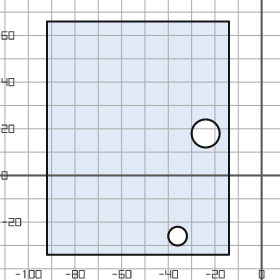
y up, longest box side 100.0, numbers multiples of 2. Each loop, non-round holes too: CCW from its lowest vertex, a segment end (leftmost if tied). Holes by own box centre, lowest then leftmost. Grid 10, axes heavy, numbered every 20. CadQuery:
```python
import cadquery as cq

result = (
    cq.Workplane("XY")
    .moveTo(-92.0, -34.0)
    .lineTo(-14.0, -34.0)
    .lineTo(-14.0, 66.0)
    .lineTo(-92.0, 66.0)
    .close()
    .moveTo(-36.0, -26.0)
    .circle(4.0)
    .moveTo(-24.0, 18.0)
    .circle(6.0)
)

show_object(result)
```